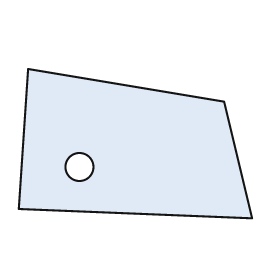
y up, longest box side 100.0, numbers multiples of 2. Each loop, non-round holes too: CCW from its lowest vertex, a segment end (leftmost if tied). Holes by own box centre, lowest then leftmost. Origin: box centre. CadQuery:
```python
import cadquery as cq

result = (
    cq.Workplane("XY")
    .moveTo(50.0, -32.0)
    .lineTo(38.0, 18.0)
    .lineTo(-46.0, 32.0)
    .lineTo(-50.0, -28.0)
    .close()
    .moveTo(-24.0, -10.0)
    .circle(6.0)
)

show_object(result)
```